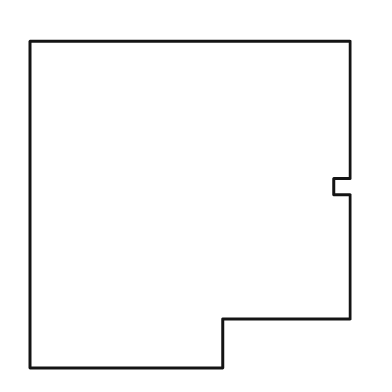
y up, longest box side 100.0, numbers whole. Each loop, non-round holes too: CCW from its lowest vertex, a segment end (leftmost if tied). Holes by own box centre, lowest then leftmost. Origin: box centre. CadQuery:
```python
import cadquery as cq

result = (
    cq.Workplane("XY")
    .moveTo(-49.0, -50.0)
    .lineTo(10.0, -50.0)
    .lineTo(10.0, -35.0)
    .lineTo(49.0, -35.0)
    .lineTo(49.0, 3.0)
    .lineTo(44.0, 3.0)
    .lineTo(44.0, 8.0)
    .lineTo(49.0, 8.0)
    .lineTo(49.0, 50.0)
    .lineTo(-49.0, 50.0)
    .close()
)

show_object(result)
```